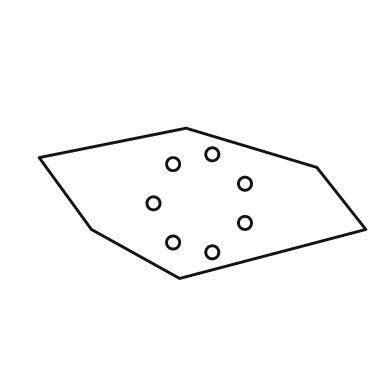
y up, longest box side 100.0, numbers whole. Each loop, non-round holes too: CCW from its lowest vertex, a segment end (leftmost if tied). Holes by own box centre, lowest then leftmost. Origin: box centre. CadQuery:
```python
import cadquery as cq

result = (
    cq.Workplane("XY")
    .moveTo(-7.0, -23.0)
    .lineTo(50.0, -8.0)
    .lineTo(35.0, 11.0)
    .lineTo(-5.0, 23.0)
    .lineTo(-50.0, 14.0)
    .lineTo(-34.0, -8.0)
    .close()
    .moveTo(3.0, -15.0)
    .circle(2.0)
    .moveTo(-9.0, -12.0)
    .circle(2.0)
    .moveTo(13.0, -6.0)
    .circle(2.0)
    .moveTo(-15.0, 0.0)
    .circle(2.0)
    .moveTo(13.0, 6.0)
    .circle(2.0)
    .moveTo(-9.0, 12.0)
    .circle(2.0)
    .moveTo(3.0, 15.0)
    .circle(2.0)
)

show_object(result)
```